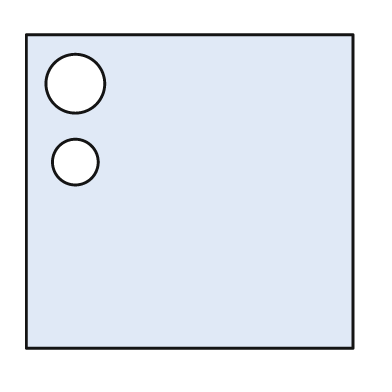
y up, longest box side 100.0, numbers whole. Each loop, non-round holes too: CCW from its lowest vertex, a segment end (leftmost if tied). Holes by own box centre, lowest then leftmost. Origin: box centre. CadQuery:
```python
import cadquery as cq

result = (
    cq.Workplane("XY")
    .moveTo(-50.0, -48.0)
    .lineTo(50.0, -48.0)
    .lineTo(50.0, 48.0)
    .lineTo(-50.0, 48.0)
    .close()
    .moveTo(-35.0, 9.0)
    .circle(7.0)
    .moveTo(-35.0, 33.0)
    .circle(9.0)
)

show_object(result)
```